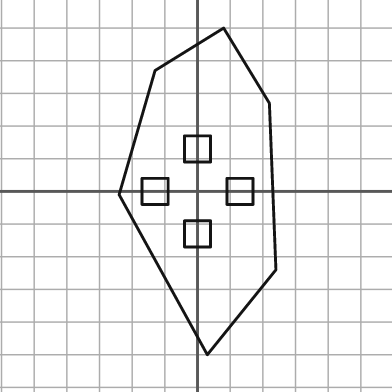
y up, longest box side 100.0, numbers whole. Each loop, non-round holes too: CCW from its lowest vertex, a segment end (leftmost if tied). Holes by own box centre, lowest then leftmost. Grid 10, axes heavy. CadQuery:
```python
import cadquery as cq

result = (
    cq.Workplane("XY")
    .moveTo(3.0, -50.0)
    .lineTo(24.0, -24.0)
    .lineTo(22.0, 27.0)
    .lineTo(8.0, 50.0)
    .lineTo(-13.0, 37.0)
    .lineTo(-24.0, -1.0)
    .close()
    .moveTo(-4.0, -17.0)
    .lineTo(4.0, -17.0)
    .lineTo(4.0, -9.0)
    .lineTo(-4.0, -9.0)
    .close()
    .moveTo(-17.0, -4.0)
    .lineTo(-9.0, -4.0)
    .lineTo(-9.0, 4.0)
    .lineTo(-17.0, 4.0)
    .close()
    .moveTo(9.0, -4.0)
    .lineTo(17.0, -4.0)
    .lineTo(17.0, 4.0)
    .lineTo(9.0, 4.0)
    .close()
    .moveTo(-4.0, 9.0)
    .lineTo(4.0, 9.0)
    .lineTo(4.0, 17.0)
    .lineTo(-4.0, 17.0)
    .close()
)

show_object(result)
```